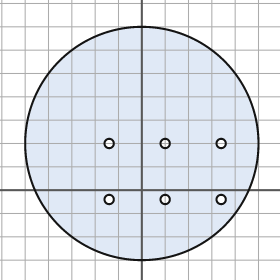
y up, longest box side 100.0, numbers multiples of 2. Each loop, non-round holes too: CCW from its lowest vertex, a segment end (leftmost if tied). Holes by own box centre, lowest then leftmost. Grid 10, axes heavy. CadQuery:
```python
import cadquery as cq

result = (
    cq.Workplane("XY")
    .moveTo(0.0, 20.0)
    .circle(50.0)
    .moveTo(-14.0, -4.0)
    .circle(2.0)
    .moveTo(10.0, -4.0)
    .circle(2.0)
    .moveTo(34.0, -4.0)
    .circle(2.0)
    .moveTo(-14.0, 20.0)
    .circle(2.0)
    .moveTo(10.0, 20.0)
    .circle(2.0)
    .moveTo(34.0, 20.0)
    .circle(2.0)
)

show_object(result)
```